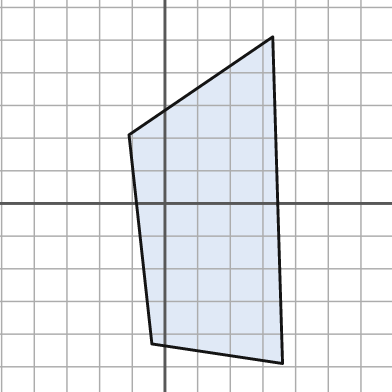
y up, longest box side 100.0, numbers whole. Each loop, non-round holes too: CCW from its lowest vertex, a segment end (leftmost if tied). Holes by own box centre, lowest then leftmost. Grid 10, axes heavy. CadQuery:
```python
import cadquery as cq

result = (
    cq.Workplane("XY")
    .moveTo(36.0, -49.0)
    .lineTo(33.0, 51.0)
    .lineTo(-11.0, 21.0)
    .lineTo(-4.0, -43.0)
    .close()
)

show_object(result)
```